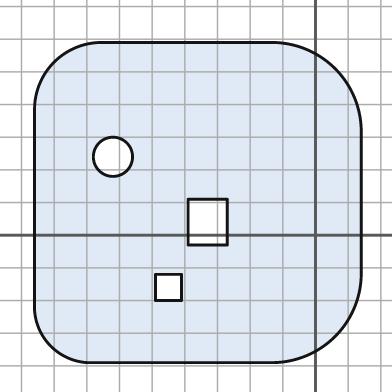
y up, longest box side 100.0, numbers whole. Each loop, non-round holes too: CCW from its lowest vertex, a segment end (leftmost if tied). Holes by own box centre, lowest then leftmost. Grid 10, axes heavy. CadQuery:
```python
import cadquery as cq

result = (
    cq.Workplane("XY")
    .moveTo(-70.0, -39.0)
    .lineTo(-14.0, -39.0)
    .threePointArc((6.0, -31.0), (14.0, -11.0))
    .lineTo(14.0, 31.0)
    .threePointArc((6.0, 51.0), (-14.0, 59.0))
    .lineTo(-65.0, 59.0)
    .threePointArc((-80.0, 53.0), (-86.0, 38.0))
    .lineTo(-86.0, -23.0)
    .threePointArc((-81.0, -34.0), (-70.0, -39.0))
    .close()
    .moveTo(-49.0, -20.0)
    .lineTo(-41.0, -20.0)
    .lineTo(-41.0, -12.0)
    .lineTo(-49.0, -12.0)
    .close()
    .moveTo(-39.0, -3.0)
    .lineTo(-27.0, -3.0)
    .lineTo(-27.0, 11.0)
    .lineTo(-39.0, 11.0)
    .close()
    .moveTo(-62.0, 24.0)
    .circle(6.0)
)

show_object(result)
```